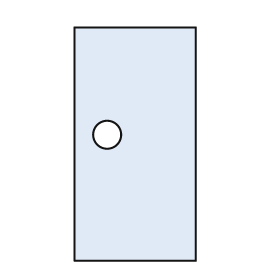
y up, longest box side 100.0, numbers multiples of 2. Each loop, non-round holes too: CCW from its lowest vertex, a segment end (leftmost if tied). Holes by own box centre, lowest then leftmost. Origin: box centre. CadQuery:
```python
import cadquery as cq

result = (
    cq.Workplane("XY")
    .moveTo(-26.0, -50.0)
    .lineTo(26.0, -50.0)
    .lineTo(26.0, 50.0)
    .lineTo(-26.0, 50.0)
    .close()
    .moveTo(-12.0, 4.0)
    .circle(6.0)
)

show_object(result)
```